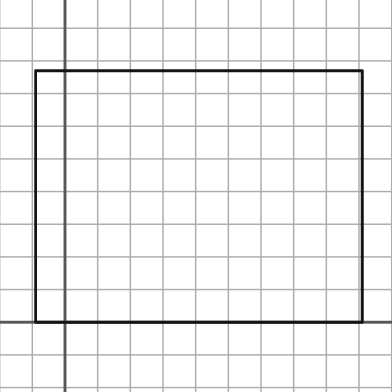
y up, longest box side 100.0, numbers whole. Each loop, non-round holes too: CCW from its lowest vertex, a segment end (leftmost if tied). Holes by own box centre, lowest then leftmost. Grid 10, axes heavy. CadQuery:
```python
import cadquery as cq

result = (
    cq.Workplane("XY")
    .moveTo(-9.0, 0.0)
    .lineTo(91.0, 0.0)
    .lineTo(91.0, 77.0)
    .lineTo(-9.0, 77.0)
    .close()
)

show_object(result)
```